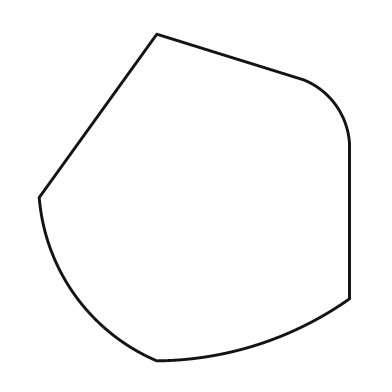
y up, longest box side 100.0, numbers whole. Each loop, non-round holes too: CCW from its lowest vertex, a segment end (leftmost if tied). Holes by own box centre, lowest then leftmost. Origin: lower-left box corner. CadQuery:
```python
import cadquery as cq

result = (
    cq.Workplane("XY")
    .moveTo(36.0, 0.0)
    .threePointArc((67.0, 5.0), (95.0, 19.0))
    .lineTo(95.0, 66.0)
    .threePointArc((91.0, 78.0), (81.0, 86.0))
    .lineTo(36.0, 100.0)
    .lineTo(0.0, 50.0)
    .threePointArc((11.0, 20.0), (36.0, 0.0))
    .close()
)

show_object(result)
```